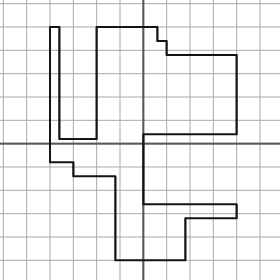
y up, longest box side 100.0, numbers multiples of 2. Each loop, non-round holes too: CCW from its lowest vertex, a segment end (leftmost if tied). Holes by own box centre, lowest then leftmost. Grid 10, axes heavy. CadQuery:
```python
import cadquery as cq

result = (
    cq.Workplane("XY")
    .moveTo(-12.0, -50.0)
    .lineTo(18.0, -50.0)
    .lineTo(18.0, -32.0)
    .lineTo(40.0, -32.0)
    .lineTo(40.0, -26.0)
    .lineTo(0.0, -26.0)
    .lineTo(0.0, 4.0)
    .lineTo(40.0, 4.0)
    .lineTo(40.0, 38.0)
    .lineTo(10.0, 38.0)
    .lineTo(10.0, 44.0)
    .lineTo(6.0, 44.0)
    .lineTo(6.0, 50.0)
    .lineTo(-20.0, 50.0)
    .lineTo(-20.0, 2.0)
    .lineTo(-36.0, 2.0)
    .lineTo(-36.0, 50.0)
    .lineTo(-40.0, 50.0)
    .lineTo(-40.0, -8.0)
    .lineTo(-30.0, -8.0)
    .lineTo(-30.0, -14.0)
    .lineTo(-12.0, -14.0)
    .close()
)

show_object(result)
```